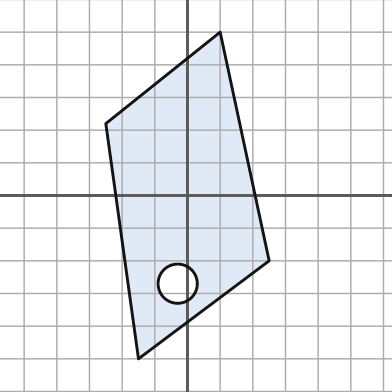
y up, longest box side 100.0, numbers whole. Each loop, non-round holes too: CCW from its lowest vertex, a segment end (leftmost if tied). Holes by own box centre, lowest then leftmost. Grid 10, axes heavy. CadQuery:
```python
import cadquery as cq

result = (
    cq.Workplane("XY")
    .moveTo(-15.0, -50.0)
    .lineTo(25.0, -20.0)
    .lineTo(10.0, 50.0)
    .lineTo(-25.0, 22.0)
    .close()
    .moveTo(-3.0, -27.0)
    .circle(6.0)
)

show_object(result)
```